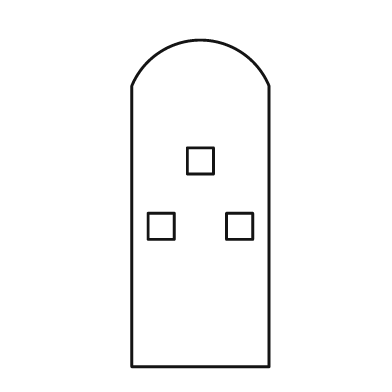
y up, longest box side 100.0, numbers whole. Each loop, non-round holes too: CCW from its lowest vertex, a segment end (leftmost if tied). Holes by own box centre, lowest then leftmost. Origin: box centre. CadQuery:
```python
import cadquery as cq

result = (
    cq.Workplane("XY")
    .moveTo(-21.0, -50.0)
    .lineTo(21.0, -50.0)
    .lineTo(21.0, 36.0)
    .threePointArc((0.0, 50.0), (-21.0, 36.0))
    .close()
    .moveTo(-16.0, -11.0)
    .lineTo(-8.0, -11.0)
    .lineTo(-8.0, -3.0)
    .lineTo(-16.0, -3.0)
    .close()
    .moveTo(8.0, -11.0)
    .lineTo(16.0, -11.0)
    .lineTo(16.0, -3.0)
    .lineTo(8.0, -3.0)
    .close()
    .moveTo(-4.0, 9.0)
    .lineTo(4.0, 9.0)
    .lineTo(4.0, 17.0)
    .lineTo(-4.0, 17.0)
    .close()
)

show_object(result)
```